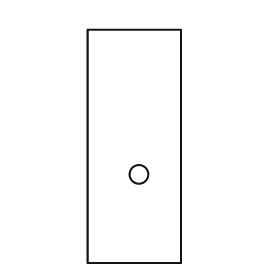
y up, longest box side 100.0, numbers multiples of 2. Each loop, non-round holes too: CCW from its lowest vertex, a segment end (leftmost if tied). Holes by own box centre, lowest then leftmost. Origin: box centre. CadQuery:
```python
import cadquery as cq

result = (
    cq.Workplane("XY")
    .moveTo(-20.0, -50.0)
    .lineTo(20.0, -50.0)
    .lineTo(20.0, 50.0)
    .lineTo(-20.0, 50.0)
    .close()
    .moveTo(2.0, -12.0)
    .circle(4.0)
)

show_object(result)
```